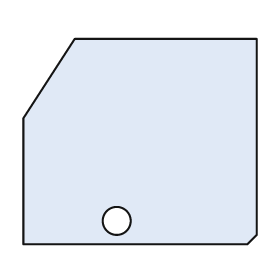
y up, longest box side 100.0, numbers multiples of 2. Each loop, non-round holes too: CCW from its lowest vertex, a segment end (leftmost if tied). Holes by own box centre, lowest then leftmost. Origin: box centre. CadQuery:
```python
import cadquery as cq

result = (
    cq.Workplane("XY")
    .moveTo(-50.0, -44.0)
    .lineTo(46.0, -44.0)
    .lineTo(50.0, -40.0)
    .lineTo(50.0, 44.0)
    .lineTo(-28.0, 44.0)
    .lineTo(-50.0, 10.0)
    .close()
    .moveTo(-10.0, -34.0)
    .circle(6.0)
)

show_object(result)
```